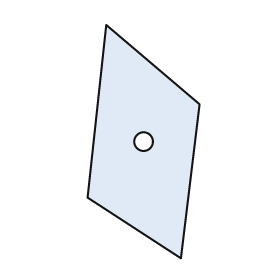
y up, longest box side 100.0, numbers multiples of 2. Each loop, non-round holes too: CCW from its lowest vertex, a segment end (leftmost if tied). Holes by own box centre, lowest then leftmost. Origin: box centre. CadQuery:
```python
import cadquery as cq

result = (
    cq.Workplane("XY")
    .moveTo(16.0, -50.0)
    .lineTo(24.0, 16.0)
    .lineTo(-16.0, 50.0)
    .lineTo(-24.0, -24.0)
    .close()
    .moveTo(0.0, 0.0)
    .circle(4.0)
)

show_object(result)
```